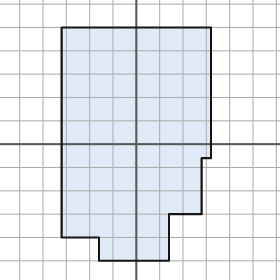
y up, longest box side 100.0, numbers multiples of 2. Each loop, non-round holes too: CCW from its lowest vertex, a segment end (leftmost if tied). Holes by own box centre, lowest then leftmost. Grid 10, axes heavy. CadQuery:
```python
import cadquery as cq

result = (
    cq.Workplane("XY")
    .moveTo(-16.0, -50.0)
    .lineTo(14.0, -50.0)
    .lineTo(14.0, -30.0)
    .lineTo(28.0, -30.0)
    .lineTo(28.0, -6.0)
    .lineTo(32.0, -6.0)
    .lineTo(32.0, 50.0)
    .lineTo(-32.0, 50.0)
    .lineTo(-32.0, -40.0)
    .lineTo(-16.0, -40.0)
    .close()
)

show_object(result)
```